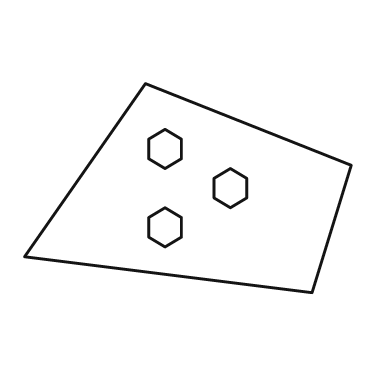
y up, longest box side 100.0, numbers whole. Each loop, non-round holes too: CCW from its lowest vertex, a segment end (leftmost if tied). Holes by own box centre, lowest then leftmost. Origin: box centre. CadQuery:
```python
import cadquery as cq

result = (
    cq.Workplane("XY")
    .moveTo(38.0, -32.0)
    .lineTo(50.0, 7.0)
    .lineTo(-13.0, 32.0)
    .lineTo(-50.0, -21.0)
    .close()
    .moveTo(-7.0, -18.0)
    .lineTo(-2.0, -15.0)
    .lineTo(-2.0, -9.0)
    .lineTo(-7.0, -6.0)
    .lineTo(-12.0, -9.0)
    .lineTo(-12.0, -15.0)
    .close()
    .moveTo(13.0, -6.0)
    .lineTo(18.0, -3.0)
    .lineTo(18.0, 3.0)
    .lineTo(13.0, 6.0)
    .lineTo(8.0, 3.0)
    .lineTo(8.0, -3.0)
    .close()
    .moveTo(-7.0, 6.0)
    .lineTo(-2.0, 9.0)
    .lineTo(-2.0, 15.0)
    .lineTo(-7.0, 18.0)
    .lineTo(-12.0, 15.0)
    .lineTo(-12.0, 9.0)
    .close()
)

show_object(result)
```